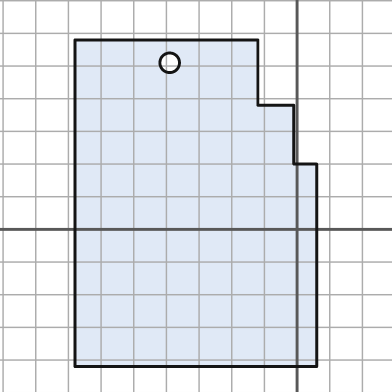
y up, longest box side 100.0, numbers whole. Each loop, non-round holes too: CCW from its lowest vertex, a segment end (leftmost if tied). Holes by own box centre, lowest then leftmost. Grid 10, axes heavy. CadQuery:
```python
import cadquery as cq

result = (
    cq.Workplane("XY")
    .moveTo(-68.0, -42.0)
    .lineTo(6.0, -42.0)
    .lineTo(6.0, 20.0)
    .lineTo(-1.0, 20.0)
    .lineTo(-1.0, 38.0)
    .lineTo(-12.0, 38.0)
    .lineTo(-12.0, 58.0)
    .lineTo(-68.0, 58.0)
    .close()
    .moveTo(-39.0, 51.0)
    .circle(3.0)
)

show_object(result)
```